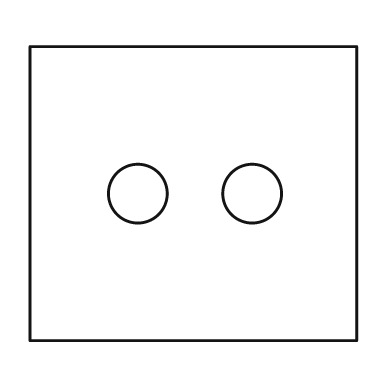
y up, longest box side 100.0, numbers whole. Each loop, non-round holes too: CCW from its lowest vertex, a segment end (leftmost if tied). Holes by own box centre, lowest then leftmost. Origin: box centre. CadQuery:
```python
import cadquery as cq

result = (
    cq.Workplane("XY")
    .moveTo(-50.0, -45.0)
    .lineTo(50.0, -45.0)
    .lineTo(50.0, 45.0)
    .lineTo(-50.0, 45.0)
    .close()
    .moveTo(-17.0, 0.0)
    .circle(9.0)
    .moveTo(18.0, 0.0)
    .circle(9.0)
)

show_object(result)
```